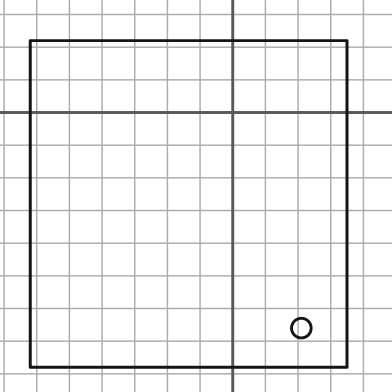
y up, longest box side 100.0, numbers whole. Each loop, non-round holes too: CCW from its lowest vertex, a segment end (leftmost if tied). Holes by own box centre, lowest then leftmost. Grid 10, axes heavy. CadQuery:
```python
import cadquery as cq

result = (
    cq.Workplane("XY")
    .moveTo(-62.0, -78.0)
    .lineTo(35.0, -78.0)
    .lineTo(35.0, 22.0)
    .lineTo(-62.0, 22.0)
    .close()
    .moveTo(21.0, -66.0)
    .circle(3.0)
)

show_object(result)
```